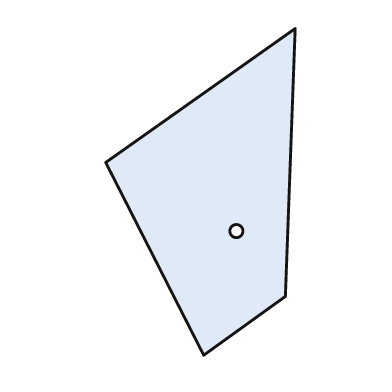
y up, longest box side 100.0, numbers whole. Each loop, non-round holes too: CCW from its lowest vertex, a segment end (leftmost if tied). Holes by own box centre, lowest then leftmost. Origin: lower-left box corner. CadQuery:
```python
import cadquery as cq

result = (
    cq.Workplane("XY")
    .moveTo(30.0, 0.0)
    .lineTo(55.0, 18.0)
    .lineTo(58.0, 100.0)
    .lineTo(0.0, 59.0)
    .close()
    .moveTo(40.0, 38.0)
    .circle(2.0)
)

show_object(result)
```